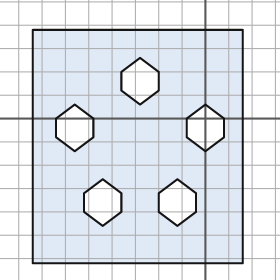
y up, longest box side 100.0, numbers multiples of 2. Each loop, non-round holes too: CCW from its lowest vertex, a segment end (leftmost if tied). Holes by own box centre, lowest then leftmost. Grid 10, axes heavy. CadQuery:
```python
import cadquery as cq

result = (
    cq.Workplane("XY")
    .moveTo(-74.0, -62.0)
    .lineTo(16.0, -62.0)
    .lineTo(16.0, 38.0)
    .lineTo(-74.0, 38.0)
    .close()
    .moveTo(-44.0, -46.0)
    .lineTo(-36.0, -40.0)
    .lineTo(-36.0, -32.0)
    .lineTo(-44.0, -26.0)
    .lineTo(-52.0, -32.0)
    .lineTo(-52.0, -40.0)
    .close()
    .moveTo(-12.0, -46.0)
    .lineTo(-4.0, -40.0)
    .lineTo(-4.0, -32.0)
    .lineTo(-12.0, -26.0)
    .lineTo(-20.0, -32.0)
    .lineTo(-20.0, -40.0)
    .close()
    .moveTo(-56.0, -14.0)
    .lineTo(-48.0, -8.0)
    .lineTo(-48.0, 0.0)
    .lineTo(-56.0, 6.0)
    .lineTo(-64.0, 0.0)
    .lineTo(-64.0, -8.0)
    .close()
    .moveTo(0.0, -14.0)
    .lineTo(8.0, -8.0)
    .lineTo(8.0, 0.0)
    .lineTo(0.0, 6.0)
    .lineTo(-8.0, 0.0)
    .lineTo(-8.0, -8.0)
    .close()
    .moveTo(-28.0, 6.0)
    .lineTo(-20.0, 12.0)
    .lineTo(-20.0, 20.0)
    .lineTo(-28.0, 26.0)
    .lineTo(-36.0, 20.0)
    .lineTo(-36.0, 12.0)
    .close()
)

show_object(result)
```